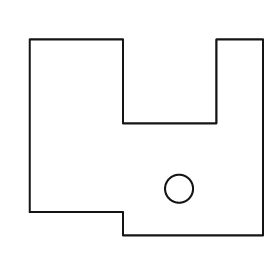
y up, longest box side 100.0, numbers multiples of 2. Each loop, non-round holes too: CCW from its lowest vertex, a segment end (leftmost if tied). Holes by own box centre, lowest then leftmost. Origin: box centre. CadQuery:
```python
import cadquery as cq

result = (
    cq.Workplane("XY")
    .moveTo(-10.0, -42.0)
    .lineTo(50.0, -42.0)
    .lineTo(50.0, 42.0)
    .lineTo(30.0, 42.0)
    .lineTo(30.0, 6.0)
    .lineTo(-10.0, 6.0)
    .lineTo(-10.0, 42.0)
    .lineTo(-50.0, 42.0)
    .lineTo(-50.0, -32.0)
    .lineTo(-10.0, -32.0)
    .close()
    .moveTo(14.0, -22.0)
    .circle(6.0)
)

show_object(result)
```